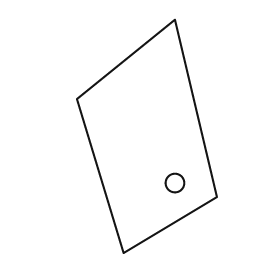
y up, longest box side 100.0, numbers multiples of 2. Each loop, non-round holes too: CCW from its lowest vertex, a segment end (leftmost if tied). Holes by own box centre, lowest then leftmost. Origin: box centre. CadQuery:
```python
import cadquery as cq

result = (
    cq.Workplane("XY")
    .moveTo(-10.0, -50.0)
    .lineTo(30.0, -26.0)
    .lineTo(12.0, 50.0)
    .lineTo(-30.0, 16.0)
    .close()
    .moveTo(12.0, -20.0)
    .circle(4.0)
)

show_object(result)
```